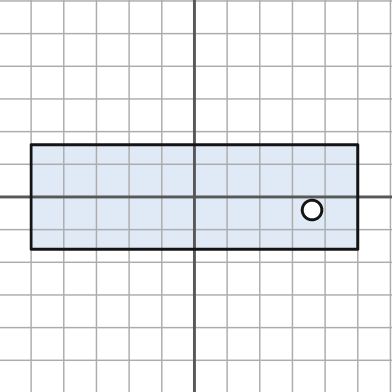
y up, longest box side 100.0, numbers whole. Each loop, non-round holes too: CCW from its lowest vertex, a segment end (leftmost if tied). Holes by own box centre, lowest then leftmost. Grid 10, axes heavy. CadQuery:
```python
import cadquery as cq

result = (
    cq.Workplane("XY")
    .moveTo(-50.0, -16.0)
    .lineTo(50.0, -16.0)
    .lineTo(50.0, 16.0)
    .lineTo(-50.0, 16.0)
    .close()
    .moveTo(36.0, -4.0)
    .circle(3.0)
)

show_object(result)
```